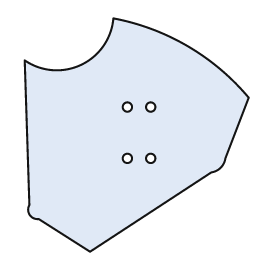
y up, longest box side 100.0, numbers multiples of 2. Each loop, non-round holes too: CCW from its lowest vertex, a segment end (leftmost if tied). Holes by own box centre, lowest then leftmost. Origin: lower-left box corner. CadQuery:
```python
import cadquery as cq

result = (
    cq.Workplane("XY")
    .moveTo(28.0, 0.0)
    .lineTo(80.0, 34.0)
    .threePointArc((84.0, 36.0), (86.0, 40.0))
    .lineTo(96.0, 66.0)
    .threePointArc((70.0, 88.0), (38.0, 100.0))
    .threePointArc((24.0, 80.0), (0.0, 82.0))
    .lineTo(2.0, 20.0)
    .threePointArc((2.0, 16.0), (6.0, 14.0))
    .close()
    .moveTo(44.0, 40.0)
    .circle(2.0)
    .moveTo(54.0, 40.0)
    .circle(2.0)
    .moveTo(44.0, 62.0)
    .circle(2.0)
    .moveTo(54.0, 62.0)
    .circle(2.0)
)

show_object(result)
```